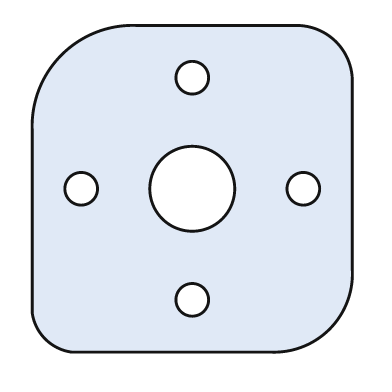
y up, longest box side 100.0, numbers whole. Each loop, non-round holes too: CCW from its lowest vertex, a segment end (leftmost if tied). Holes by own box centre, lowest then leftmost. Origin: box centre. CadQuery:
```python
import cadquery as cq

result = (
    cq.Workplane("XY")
    .moveTo(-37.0, -50.0)
    .lineTo(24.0, -50.0)
    .threePointArc((42.0, -43.0), (49.0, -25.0))
    .lineTo(49.0, 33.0)
    .threePointArc((44.0, 45.0), (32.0, 50.0))
    .lineTo(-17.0, 50.0)
    .threePointArc((-40.0, 41.0), (-49.0, 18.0))
    .lineTo(-49.0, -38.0)
    .threePointArc((-45.0, -46.0), (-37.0, -50.0))
    .close()
    .moveTo(0.0, -34.0)
    .circle(5.0)
    .moveTo(-34.0, 0.0)
    .circle(5.0)
    .moveTo(0.0, 0.0)
    .circle(13.0)
    .moveTo(34.0, 0.0)
    .circle(5.0)
    .moveTo(0.0, 34.0)
    .circle(5.0)
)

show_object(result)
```